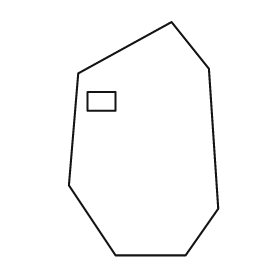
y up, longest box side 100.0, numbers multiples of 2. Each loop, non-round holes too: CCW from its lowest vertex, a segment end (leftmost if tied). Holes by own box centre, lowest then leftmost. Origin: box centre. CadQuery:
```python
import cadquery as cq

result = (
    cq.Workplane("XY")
    .moveTo(-12.0, -50.0)
    .lineTo(18.0, -50.0)
    .lineTo(32.0, -30.0)
    .lineTo(28.0, 30.0)
    .lineTo(12.0, 50.0)
    .lineTo(-28.0, 28.0)
    .lineTo(-32.0, -20.0)
    .close()
    .moveTo(-24.0, 12.0)
    .lineTo(-12.0, 12.0)
    .lineTo(-12.0, 20.0)
    .lineTo(-24.0, 20.0)
    .close()
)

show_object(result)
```